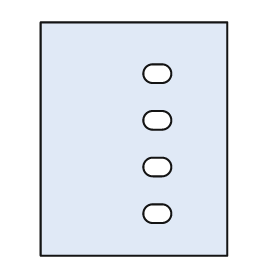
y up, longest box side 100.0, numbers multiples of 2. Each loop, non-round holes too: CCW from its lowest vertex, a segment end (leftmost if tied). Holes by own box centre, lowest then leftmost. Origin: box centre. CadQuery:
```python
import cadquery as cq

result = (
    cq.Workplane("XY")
    .moveTo(-40.0, -50.0)
    .lineTo(40.0, -50.0)
    .lineTo(40.0, 50.0)
    .lineTo(-40.0, 50.0)
    .close()
    .moveTo(8.0, -36.0)
    .lineTo(12.0, -36.0)
    .threePointArc((16.0, -32.0), (12.0, -28.0))
    .lineTo(8.0, -28.0)
    .threePointArc((4.0, -32.0), (8.0, -36.0))
    .close()
    .moveTo(8.0, -16.0)
    .lineTo(12.0, -16.0)
    .threePointArc((16.0, -12.0), (12.0, -8.0))
    .lineTo(8.0, -8.0)
    .threePointArc((4.0, -12.0), (8.0, -16.0))
    .close()
    .moveTo(8.0, 4.0)
    .lineTo(12.0, 4.0)
    .threePointArc((16.0, 8.0), (12.0, 12.0))
    .lineTo(8.0, 12.0)
    .threePointArc((4.0, 8.0), (8.0, 4.0))
    .close()
    .moveTo(8.0, 24.0)
    .lineTo(12.0, 24.0)
    .threePointArc((16.0, 28.0), (12.0, 32.0))
    .lineTo(8.0, 32.0)
    .threePointArc((4.0, 28.0), (8.0, 24.0))
    .close()
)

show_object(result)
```